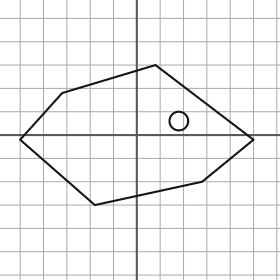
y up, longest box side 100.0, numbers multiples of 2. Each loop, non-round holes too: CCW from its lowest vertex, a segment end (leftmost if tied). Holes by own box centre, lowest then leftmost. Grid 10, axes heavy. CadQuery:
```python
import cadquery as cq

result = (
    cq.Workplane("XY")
    .moveTo(-18.0, -30.0)
    .lineTo(28.0, -20.0)
    .lineTo(50.0, -2.0)
    .lineTo(8.0, 30.0)
    .lineTo(-32.0, 18.0)
    .lineTo(-50.0, -2.0)
    .close()
    .moveTo(18.0, 6.0)
    .circle(4.0)
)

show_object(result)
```